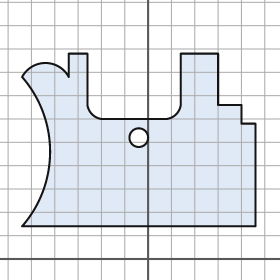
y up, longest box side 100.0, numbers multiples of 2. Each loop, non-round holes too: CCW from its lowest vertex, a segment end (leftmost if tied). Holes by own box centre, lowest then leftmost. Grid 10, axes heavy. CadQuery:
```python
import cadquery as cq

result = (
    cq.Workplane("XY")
    .moveTo(-54.0, 14.0)
    .lineTo(46.0, 14.0)
    .lineTo(46.0, 58.0)
    .lineTo(40.0, 58.0)
    .lineTo(40.0, 66.0)
    .lineTo(30.0, 66.0)
    .lineTo(30.0, 88.0)
    .lineTo(14.0, 88.0)
    .lineTo(14.0, 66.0)
    .threePointArc((12.0, 62.0), (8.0, 60.0))
    .lineTo(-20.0, 60.0)
    .threePointArc((-24.0, 62.0), (-26.0, 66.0))
    .lineTo(-26.0, 88.0)
    .lineTo(-34.0, 88.0)
    .lineTo(-34.0, 78.0)
    .threePointArc((-44.0, 84.0), (-54.0, 78.0))
    .threePointArc((-42.0, 46.0), (-54.0, 14.0))
    .close()
    .moveTo(-4.0, 52.0)
    .circle(4.0)
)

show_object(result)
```